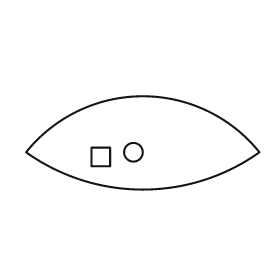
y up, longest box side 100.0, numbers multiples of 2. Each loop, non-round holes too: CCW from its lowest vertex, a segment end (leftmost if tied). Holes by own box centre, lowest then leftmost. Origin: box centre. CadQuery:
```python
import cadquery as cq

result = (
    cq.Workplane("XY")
    .moveTo(-50.0, -4.0)
    .threePointArc((0.0, -20.0), (50.0, -4.0))
    .threePointArc((0.0, 20.0), (-50.0, -4.0))
    .close()
    .moveTo(-22.0, -10.0)
    .lineTo(-14.0, -10.0)
    .lineTo(-14.0, -2.0)
    .lineTo(-22.0, -2.0)
    .close()
    .moveTo(-4.0, -4.0)
    .circle(4.0)
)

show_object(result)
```